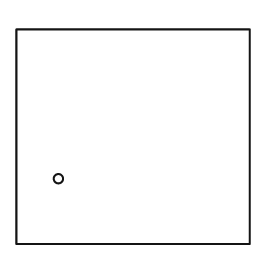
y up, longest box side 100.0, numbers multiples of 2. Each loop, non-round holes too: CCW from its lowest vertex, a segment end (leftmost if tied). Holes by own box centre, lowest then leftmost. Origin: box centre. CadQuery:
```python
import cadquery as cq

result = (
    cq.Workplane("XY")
    .moveTo(-50.0, -46.0)
    .lineTo(50.0, -46.0)
    .lineTo(50.0, 46.0)
    .lineTo(-50.0, 46.0)
    .close()
    .moveTo(-32.0, -18.0)
    .circle(2.0)
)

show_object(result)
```